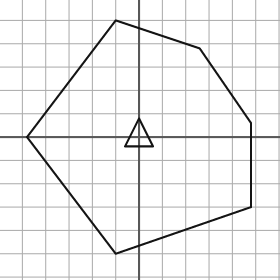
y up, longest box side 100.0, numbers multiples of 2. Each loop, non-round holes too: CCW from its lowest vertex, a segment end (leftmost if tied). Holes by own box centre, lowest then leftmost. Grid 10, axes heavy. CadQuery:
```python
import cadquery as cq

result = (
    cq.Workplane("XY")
    .moveTo(-10.0, -50.0)
    .lineTo(48.0, -30.0)
    .lineTo(48.0, 6.0)
    .lineTo(26.0, 38.0)
    .lineTo(-10.0, 50.0)
    .lineTo(-48.0, 0.0)
    .close()
    .moveTo(-6.0, -4.0)
    .lineTo(6.0, -4.0)
    .lineTo(0.0, 8.0)
    .close()
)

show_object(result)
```